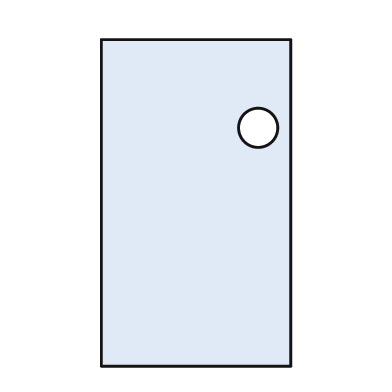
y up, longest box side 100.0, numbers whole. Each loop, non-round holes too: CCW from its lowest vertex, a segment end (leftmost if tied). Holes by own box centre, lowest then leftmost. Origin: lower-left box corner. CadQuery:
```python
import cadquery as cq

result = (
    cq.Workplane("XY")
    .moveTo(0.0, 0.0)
    .lineTo(58.0, 0.0)
    .lineTo(58.0, 100.0)
    .lineTo(0.0, 100.0)
    .close()
    .moveTo(48.0, 73.0)
    .circle(6.0)
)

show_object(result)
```